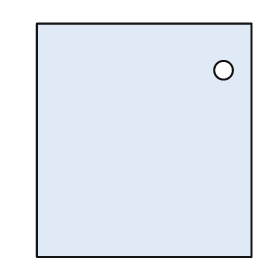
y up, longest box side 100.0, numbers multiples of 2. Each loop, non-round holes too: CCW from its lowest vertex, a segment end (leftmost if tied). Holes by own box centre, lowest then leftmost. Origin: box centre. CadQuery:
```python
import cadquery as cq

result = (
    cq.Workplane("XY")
    .moveTo(-46.0, -50.0)
    .lineTo(46.0, -50.0)
    .lineTo(46.0, 50.0)
    .lineTo(-46.0, 50.0)
    .close()
    .moveTo(34.0, 30.0)
    .circle(4.0)
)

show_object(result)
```